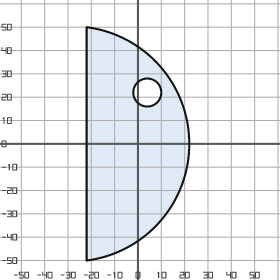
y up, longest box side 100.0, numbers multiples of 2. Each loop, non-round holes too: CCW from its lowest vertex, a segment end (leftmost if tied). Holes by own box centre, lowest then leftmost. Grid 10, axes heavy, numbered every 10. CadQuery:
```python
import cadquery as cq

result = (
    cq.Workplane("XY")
    .moveTo(-22.0, -50.0)
    .threePointArc((22.0, 0.0), (-22.0, 50.0))
    .close()
    .moveTo(4.0, 22.0)
    .circle(6.0)
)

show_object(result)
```